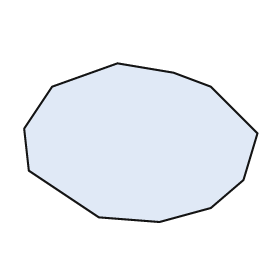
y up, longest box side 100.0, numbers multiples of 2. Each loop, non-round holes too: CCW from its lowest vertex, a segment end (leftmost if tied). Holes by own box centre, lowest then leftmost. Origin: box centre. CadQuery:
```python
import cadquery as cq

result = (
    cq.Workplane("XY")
    .moveTo(8.0, -34.0)
    .lineTo(30.0, -28.0)
    .lineTo(44.0, -16.0)
    .lineTo(50.0, 4.0)
    .lineTo(30.0, 24.0)
    .lineTo(14.0, 30.0)
    .lineTo(-10.0, 34.0)
    .lineTo(-38.0, 24.0)
    .lineTo(-50.0, 6.0)
    .lineTo(-48.0, -12.0)
    .lineTo(-18.0, -32.0)
    .close()
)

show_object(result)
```